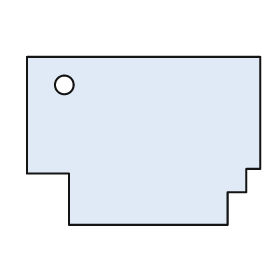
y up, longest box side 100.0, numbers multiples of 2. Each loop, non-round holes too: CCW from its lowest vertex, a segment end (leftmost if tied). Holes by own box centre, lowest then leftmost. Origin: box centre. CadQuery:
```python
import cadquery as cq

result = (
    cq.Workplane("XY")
    .moveTo(-32.0, -36.0)
    .lineTo(36.0, -36.0)
    .lineTo(36.0, -22.0)
    .lineTo(44.0, -22.0)
    .lineTo(44.0, -12.0)
    .lineTo(50.0, -12.0)
    .lineTo(50.0, 36.0)
    .lineTo(-50.0, 36.0)
    .lineTo(-50.0, -14.0)
    .lineTo(-32.0, -14.0)
    .close()
    .moveTo(-34.0, 24.0)
    .circle(4.0)
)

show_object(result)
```